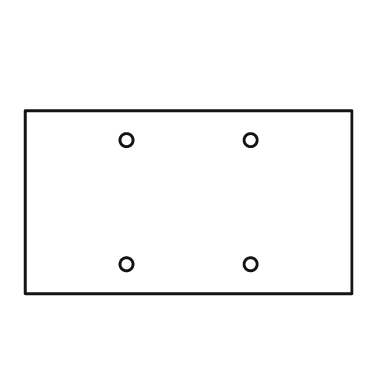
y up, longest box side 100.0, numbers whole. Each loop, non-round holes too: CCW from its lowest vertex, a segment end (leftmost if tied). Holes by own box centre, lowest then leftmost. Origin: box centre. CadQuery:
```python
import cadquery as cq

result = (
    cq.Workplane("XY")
    .moveTo(-50.0, -28.0)
    .lineTo(50.0, -28.0)
    .lineTo(50.0, 28.0)
    .lineTo(-50.0, 28.0)
    .close()
    .moveTo(-19.0, -19.0)
    .circle(2.0)
    .moveTo(19.0, -19.0)
    .circle(2.0)
    .moveTo(-19.0, 19.0)
    .circle(2.0)
    .moveTo(19.0, 19.0)
    .circle(2.0)
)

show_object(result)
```